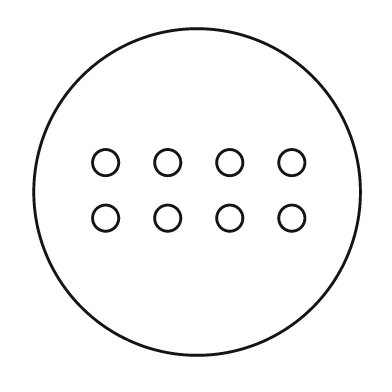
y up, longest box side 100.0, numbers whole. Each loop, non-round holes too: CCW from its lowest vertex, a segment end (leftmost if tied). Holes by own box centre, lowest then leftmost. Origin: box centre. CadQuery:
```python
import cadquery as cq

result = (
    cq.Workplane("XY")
    .moveTo(0.0, 0.0)
    .circle(50.0)
    .moveTo(-28.0, -8.0)
    .circle(4.0)
    .moveTo(-9.0, -8.0)
    .circle(4.0)
    .moveTo(10.0, -8.0)
    .circle(4.0)
    .moveTo(29.0, -8.0)
    .circle(4.0)
    .moveTo(-28.0, 9.0)
    .circle(4.0)
    .moveTo(-9.0, 9.0)
    .circle(4.0)
    .moveTo(10.0, 9.0)
    .circle(4.0)
    .moveTo(29.0, 9.0)
    .circle(4.0)
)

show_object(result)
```